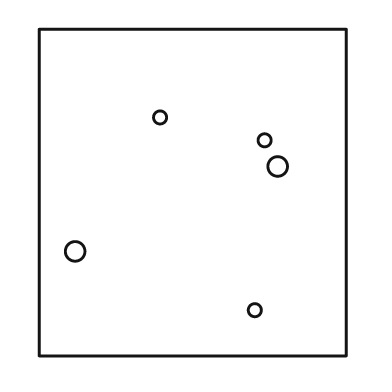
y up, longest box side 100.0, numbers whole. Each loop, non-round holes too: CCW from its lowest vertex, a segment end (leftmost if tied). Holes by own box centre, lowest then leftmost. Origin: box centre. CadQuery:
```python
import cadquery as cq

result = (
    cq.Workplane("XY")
    .moveTo(-47.0, -50.0)
    .lineTo(47.0, -50.0)
    .lineTo(47.0, 50.0)
    .lineTo(-47.0, 50.0)
    .close()
    .moveTo(19.0, -36.0)
    .circle(2.0)
    .moveTo(-36.0, -18.0)
    .circle(3.0)
    .moveTo(26.0, 8.0)
    .circle(3.0)
    .moveTo(22.0, 16.0)
    .circle(2.0)
    .moveTo(-10.0, 23.0)
    .circle(2.0)
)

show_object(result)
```